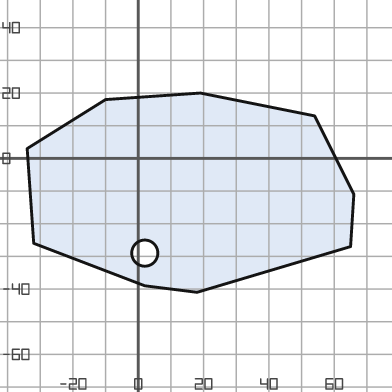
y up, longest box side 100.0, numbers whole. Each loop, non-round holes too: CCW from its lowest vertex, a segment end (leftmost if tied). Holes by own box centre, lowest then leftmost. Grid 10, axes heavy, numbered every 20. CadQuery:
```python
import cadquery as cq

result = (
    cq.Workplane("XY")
    .moveTo(18.0, -41.0)
    .lineTo(65.0, -27.0)
    .lineTo(66.0, -11.0)
    .lineTo(54.0, 13.0)
    .lineTo(19.0, 20.0)
    .lineTo(-10.0, 18.0)
    .lineTo(-34.0, 3.0)
    .lineTo(-32.0, -26.0)
    .lineTo(2.0, -39.0)
    .close()
    .moveTo(2.0, -29.0)
    .circle(4.0)
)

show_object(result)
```